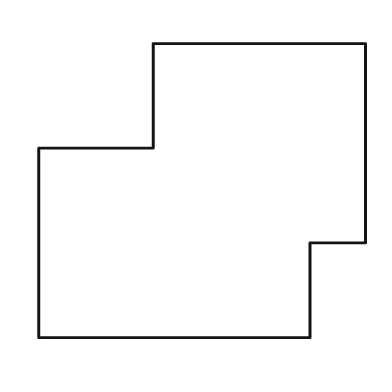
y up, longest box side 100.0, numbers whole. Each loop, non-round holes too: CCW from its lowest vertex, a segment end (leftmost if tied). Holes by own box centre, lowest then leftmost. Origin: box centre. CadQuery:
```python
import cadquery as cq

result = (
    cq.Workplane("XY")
    .moveTo(-50.0, -45.0)
    .lineTo(33.0, -45.0)
    .lineTo(33.0, -16.0)
    .lineTo(50.0, -16.0)
    .lineTo(50.0, 45.0)
    .lineTo(-15.0, 45.0)
    .lineTo(-15.0, 13.0)
    .lineTo(-50.0, 13.0)
    .close()
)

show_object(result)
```